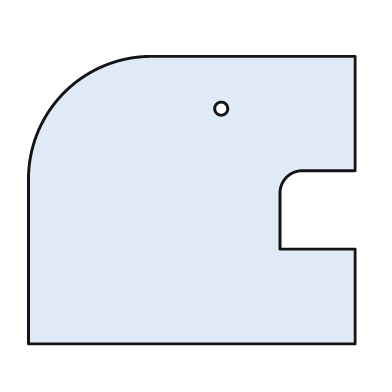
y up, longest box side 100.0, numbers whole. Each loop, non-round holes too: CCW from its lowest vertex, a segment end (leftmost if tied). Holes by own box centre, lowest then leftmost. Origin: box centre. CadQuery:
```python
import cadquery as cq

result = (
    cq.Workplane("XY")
    .moveTo(-50.0, -44.0)
    .lineTo(50.0, -44.0)
    .lineTo(50.0, -15.0)
    .lineTo(27.0, -15.0)
    .lineTo(27.0, 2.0)
    .threePointArc((29.0, 7.0), (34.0, 9.0))
    .lineTo(50.0, 9.0)
    .lineTo(50.0, 44.0)
    .lineTo(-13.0, 44.0)
    .threePointArc((-39.0, 33.0), (-50.0, 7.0))
    .close()
    .moveTo(9.0, 28.0)
    .circle(2.0)
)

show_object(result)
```